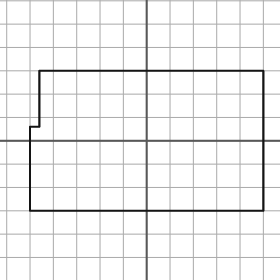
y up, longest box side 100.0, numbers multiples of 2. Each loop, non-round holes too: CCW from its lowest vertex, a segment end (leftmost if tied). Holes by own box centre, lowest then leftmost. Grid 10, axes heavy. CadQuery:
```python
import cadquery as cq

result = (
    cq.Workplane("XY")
    .moveTo(-50.0, -30.0)
    .lineTo(50.0, -30.0)
    .lineTo(50.0, 30.0)
    .lineTo(-46.0, 30.0)
    .lineTo(-46.0, 6.0)
    .lineTo(-50.0, 6.0)
    .close()
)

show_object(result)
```